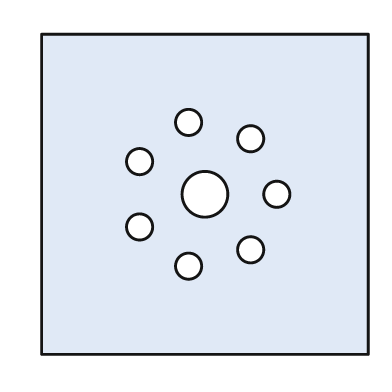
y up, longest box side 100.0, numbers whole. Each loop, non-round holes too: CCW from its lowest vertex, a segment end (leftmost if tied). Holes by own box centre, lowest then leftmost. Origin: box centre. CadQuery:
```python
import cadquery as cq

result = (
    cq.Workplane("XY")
    .moveTo(-50.0, -49.0)
    .lineTo(50.0, -49.0)
    .lineTo(50.0, 49.0)
    .lineTo(-50.0, 49.0)
    .close()
    .moveTo(-5.0, -22.0)
    .circle(4.0)
    .moveTo(14.0, -17.0)
    .circle(4.0)
    .moveTo(-20.0, -10.0)
    .circle(4.0)
    .moveTo(0.0, 0.0)
    .circle(7.0)
    .moveTo(22.0, 0.0)
    .circle(4.0)
    .moveTo(-20.0, 10.0)
    .circle(4.0)
    .moveTo(14.0, 17.0)
    .circle(4.0)
    .moveTo(-5.0, 22.0)
    .circle(4.0)
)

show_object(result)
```